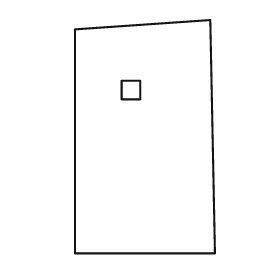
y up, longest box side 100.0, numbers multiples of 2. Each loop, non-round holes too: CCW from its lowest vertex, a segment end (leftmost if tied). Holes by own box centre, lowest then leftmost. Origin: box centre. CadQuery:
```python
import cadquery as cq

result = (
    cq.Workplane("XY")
    .moveTo(-30.0, -50.0)
    .lineTo(30.0, -50.0)
    .lineTo(28.0, 50.0)
    .lineTo(-30.0, 46.0)
    .close()
    .moveTo(-10.0, 16.0)
    .lineTo(-2.0, 16.0)
    .lineTo(-2.0, 24.0)
    .lineTo(-10.0, 24.0)
    .close()
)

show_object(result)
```